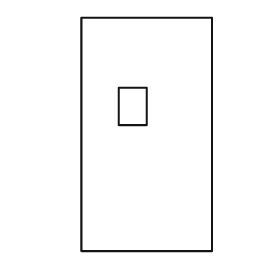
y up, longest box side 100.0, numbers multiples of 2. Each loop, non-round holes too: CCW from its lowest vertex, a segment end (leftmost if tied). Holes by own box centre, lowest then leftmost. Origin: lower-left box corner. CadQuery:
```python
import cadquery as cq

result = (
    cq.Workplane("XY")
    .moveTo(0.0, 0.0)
    .lineTo(56.0, 0.0)
    .lineTo(56.0, 100.0)
    .lineTo(0.0, 100.0)
    .close()
    .moveTo(16.0, 54.0)
    .lineTo(28.0, 54.0)
    .lineTo(28.0, 70.0)
    .lineTo(16.0, 70.0)
    .close()
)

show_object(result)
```